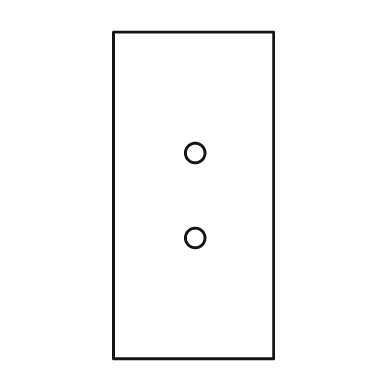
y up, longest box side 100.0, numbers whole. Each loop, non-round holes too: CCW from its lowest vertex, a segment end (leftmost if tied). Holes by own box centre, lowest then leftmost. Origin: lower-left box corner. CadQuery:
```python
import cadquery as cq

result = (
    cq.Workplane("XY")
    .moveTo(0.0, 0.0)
    .lineTo(49.0, 0.0)
    .lineTo(49.0, 100.0)
    .lineTo(0.0, 100.0)
    .close()
    .moveTo(25.0, 37.0)
    .circle(3.0)
    .moveTo(25.0, 63.0)
    .circle(3.0)
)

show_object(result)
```